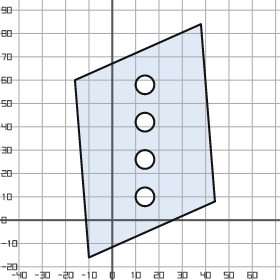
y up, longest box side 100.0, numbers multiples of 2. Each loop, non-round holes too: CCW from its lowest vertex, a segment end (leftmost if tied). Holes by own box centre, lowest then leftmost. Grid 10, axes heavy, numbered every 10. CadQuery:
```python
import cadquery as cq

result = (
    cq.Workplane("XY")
    .moveTo(-10.0, -16.0)
    .lineTo(44.0, 8.0)
    .lineTo(38.0, 84.0)
    .lineTo(-16.0, 60.0)
    .close()
    .moveTo(14.0, 10.0)
    .circle(4.0)
    .moveTo(14.0, 26.0)
    .circle(4.0)
    .moveTo(14.0, 42.0)
    .circle(4.0)
    .moveTo(14.0, 58.0)
    .circle(4.0)
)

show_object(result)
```